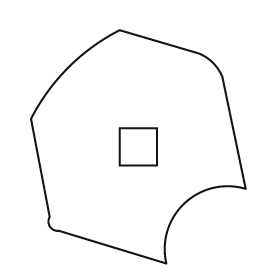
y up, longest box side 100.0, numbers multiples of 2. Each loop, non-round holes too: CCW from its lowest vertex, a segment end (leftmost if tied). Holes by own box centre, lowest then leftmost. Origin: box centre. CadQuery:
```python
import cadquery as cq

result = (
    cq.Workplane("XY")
    .moveTo(12.0, -50.0)
    .threePointArc((20.0, -24.0), (46.0, -18.0))
    .lineTo(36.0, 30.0)
    .threePointArc((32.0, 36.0), (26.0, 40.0))
    .lineTo(-8.0, 50.0)
    .threePointArc((-30.0, 34.0), (-46.0, 12.0))
    .lineTo(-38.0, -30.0)
    .threePointArc((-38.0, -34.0), (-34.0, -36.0))
    .close()
    .moveTo(-8.0, -8.0)
    .lineTo(8.0, -8.0)
    .lineTo(8.0, 8.0)
    .lineTo(-8.0, 8.0)
    .close()
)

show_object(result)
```